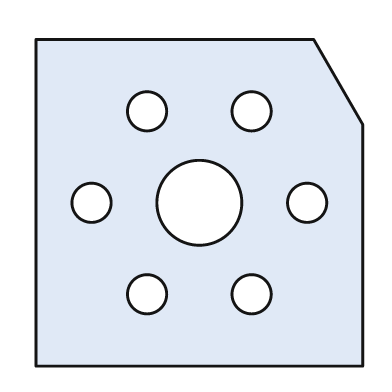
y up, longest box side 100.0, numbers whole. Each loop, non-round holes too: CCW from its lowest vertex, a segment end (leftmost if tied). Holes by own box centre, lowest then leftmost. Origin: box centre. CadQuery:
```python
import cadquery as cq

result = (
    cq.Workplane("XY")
    .moveTo(-50.0, -50.0)
    .lineTo(50.0, -50.0)
    .lineTo(50.0, 24.0)
    .lineTo(35.0, 50.0)
    .lineTo(-50.0, 50.0)
    .close()
    .moveTo(-16.0, -28.0)
    .circle(6.0)
    .moveTo(16.0, -28.0)
    .circle(6.0)
    .moveTo(-33.0, 0.0)
    .circle(6.0)
    .moveTo(0.0, 0.0)
    .circle(13.0)
    .moveTo(33.0, 0.0)
    .circle(6.0)
    .moveTo(-16.0, 28.0)
    .circle(6.0)
    .moveTo(16.0, 28.0)
    .circle(6.0)
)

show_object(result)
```